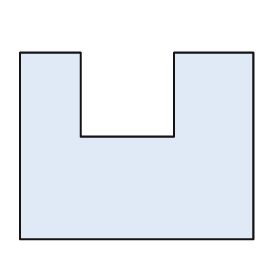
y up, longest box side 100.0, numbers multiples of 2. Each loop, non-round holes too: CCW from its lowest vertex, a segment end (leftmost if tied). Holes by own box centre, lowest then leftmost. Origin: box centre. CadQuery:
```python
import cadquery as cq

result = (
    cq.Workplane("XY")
    .moveTo(-50.0, -40.0)
    .lineTo(50.0, -40.0)
    .lineTo(50.0, 40.0)
    .lineTo(16.0, 40.0)
    .lineTo(16.0, 4.0)
    .lineTo(-24.0, 4.0)
    .lineTo(-24.0, 40.0)
    .lineTo(-50.0, 40.0)
    .close()
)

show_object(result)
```